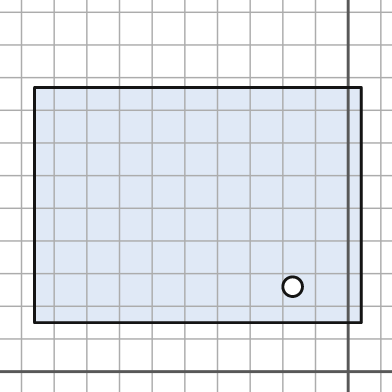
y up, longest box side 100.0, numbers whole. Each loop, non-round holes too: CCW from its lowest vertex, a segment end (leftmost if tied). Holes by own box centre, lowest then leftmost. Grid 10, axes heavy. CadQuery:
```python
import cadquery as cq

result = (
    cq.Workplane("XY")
    .moveTo(-96.0, 15.0)
    .lineTo(4.0, 15.0)
    .lineTo(4.0, 87.0)
    .lineTo(-96.0, 87.0)
    .close()
    .moveTo(-17.0, 26.0)
    .circle(3.0)
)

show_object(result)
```